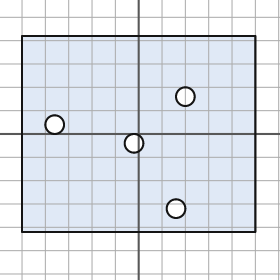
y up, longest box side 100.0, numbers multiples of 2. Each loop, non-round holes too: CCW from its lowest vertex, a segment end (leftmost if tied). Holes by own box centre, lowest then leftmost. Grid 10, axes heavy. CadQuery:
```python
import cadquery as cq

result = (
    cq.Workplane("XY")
    .moveTo(-50.0, -42.0)
    .lineTo(50.0, -42.0)
    .lineTo(50.0, 42.0)
    .lineTo(-50.0, 42.0)
    .close()
    .moveTo(16.0, -32.0)
    .circle(4.0)
    .moveTo(-2.0, -4.0)
    .circle(4.0)
    .moveTo(-36.0, 4.0)
    .circle(4.0)
    .moveTo(20.0, 16.0)
    .circle(4.0)
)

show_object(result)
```